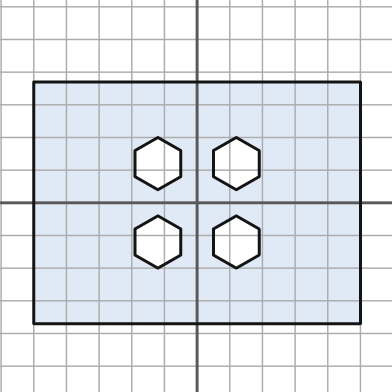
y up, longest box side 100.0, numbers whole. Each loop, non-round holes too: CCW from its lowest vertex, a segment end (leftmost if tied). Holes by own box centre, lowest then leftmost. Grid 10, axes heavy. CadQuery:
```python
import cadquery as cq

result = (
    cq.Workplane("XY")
    .moveTo(-50.0, -37.0)
    .lineTo(50.0, -37.0)
    .lineTo(50.0, 37.0)
    .lineTo(-50.0, 37.0)
    .close()
    .moveTo(-12.0, -20.0)
    .lineTo(-5.0, -16.0)
    .lineTo(-5.0, -8.0)
    .lineTo(-12.0, -4.0)
    .lineTo(-19.0, -8.0)
    .lineTo(-19.0, -16.0)
    .close()
    .moveTo(12.0, -20.0)
    .lineTo(19.0, -16.0)
    .lineTo(19.0, -8.0)
    .lineTo(12.0, -4.0)
    .lineTo(5.0, -8.0)
    .lineTo(5.0, -16.0)
    .close()
    .moveTo(-12.0, 4.0)
    .lineTo(-5.0, 8.0)
    .lineTo(-5.0, 16.0)
    .lineTo(-12.0, 20.0)
    .lineTo(-19.0, 16.0)
    .lineTo(-19.0, 8.0)
    .close()
    .moveTo(12.0, 4.0)
    .lineTo(19.0, 8.0)
    .lineTo(19.0, 16.0)
    .lineTo(12.0, 20.0)
    .lineTo(5.0, 16.0)
    .lineTo(5.0, 8.0)
    .close()
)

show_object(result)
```